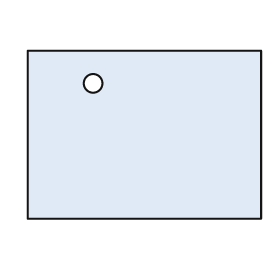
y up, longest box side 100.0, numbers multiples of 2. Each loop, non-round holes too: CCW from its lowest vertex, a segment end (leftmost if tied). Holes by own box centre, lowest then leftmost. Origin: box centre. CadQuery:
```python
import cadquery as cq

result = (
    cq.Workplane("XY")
    .moveTo(-50.0, -36.0)
    .lineTo(50.0, -36.0)
    .lineTo(50.0, 36.0)
    .lineTo(-50.0, 36.0)
    .close()
    .moveTo(-22.0, 22.0)
    .circle(4.0)
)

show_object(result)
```